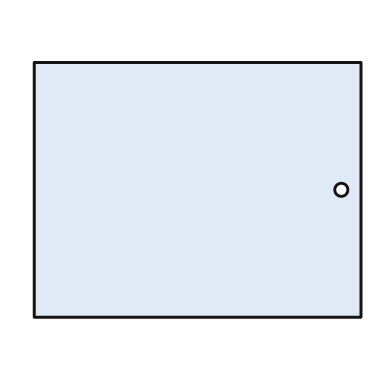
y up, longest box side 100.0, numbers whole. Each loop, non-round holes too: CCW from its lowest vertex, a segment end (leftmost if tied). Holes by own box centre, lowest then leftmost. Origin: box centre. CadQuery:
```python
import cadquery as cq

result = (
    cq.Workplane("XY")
    .moveTo(-50.0, -39.0)
    .lineTo(50.0, -39.0)
    .lineTo(50.0, 39.0)
    .lineTo(-50.0, 39.0)
    .close()
    .moveTo(44.0, 0.0)
    .circle(2.0)
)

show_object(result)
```